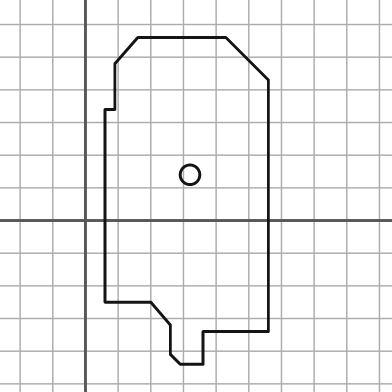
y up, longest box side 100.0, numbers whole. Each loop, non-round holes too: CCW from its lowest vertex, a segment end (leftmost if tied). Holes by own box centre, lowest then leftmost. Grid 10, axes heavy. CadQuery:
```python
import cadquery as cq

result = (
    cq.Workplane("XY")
    .moveTo(29.0, -44.0)
    .lineTo(36.0, -44.0)
    .lineTo(36.0, -34.0)
    .lineTo(56.0, -34.0)
    .lineTo(56.0, 43.0)
    .lineTo(43.0, 56.0)
    .lineTo(16.0, 56.0)
    .lineTo(9.0, 48.0)
    .lineTo(9.0, 34.0)
    .lineTo(6.0, 34.0)
    .lineTo(6.0, -25.0)
    .lineTo(20.0, -25.0)
    .lineTo(26.0, -32.0)
    .lineTo(26.0, -41.0)
    .close()
    .moveTo(32.0, 14.0)
    .circle(3.0)
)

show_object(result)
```